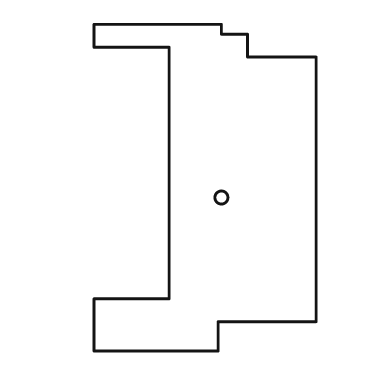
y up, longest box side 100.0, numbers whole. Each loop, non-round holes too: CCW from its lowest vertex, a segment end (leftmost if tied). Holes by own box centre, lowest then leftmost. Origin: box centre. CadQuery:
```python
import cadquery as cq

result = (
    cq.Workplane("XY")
    .moveTo(-34.0, -50.0)
    .lineTo(4.0, -50.0)
    .lineTo(4.0, -41.0)
    .lineTo(34.0, -41.0)
    .lineTo(34.0, 40.0)
    .lineTo(13.0, 40.0)
    .lineTo(13.0, 47.0)
    .lineTo(5.0, 47.0)
    .lineTo(5.0, 50.0)
    .lineTo(-34.0, 50.0)
    .lineTo(-34.0, 43.0)
    .lineTo(-11.0, 43.0)
    .lineTo(-11.0, -34.0)
    .lineTo(-34.0, -34.0)
    .close()
    .moveTo(5.0, -3.0)
    .circle(2.0)
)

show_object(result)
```